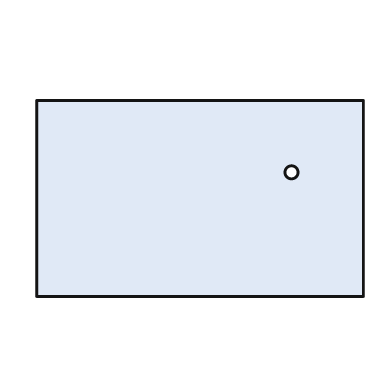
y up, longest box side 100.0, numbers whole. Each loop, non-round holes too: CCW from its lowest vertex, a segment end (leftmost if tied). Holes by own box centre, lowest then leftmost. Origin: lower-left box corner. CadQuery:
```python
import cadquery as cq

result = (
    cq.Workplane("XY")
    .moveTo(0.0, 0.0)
    .lineTo(100.0, 0.0)
    .lineTo(100.0, 60.0)
    .lineTo(0.0, 60.0)
    .close()
    .moveTo(78.0, 38.0)
    .circle(2.0)
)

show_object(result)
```